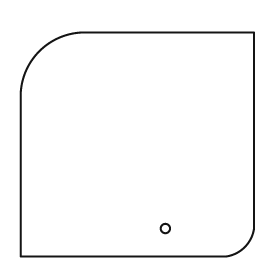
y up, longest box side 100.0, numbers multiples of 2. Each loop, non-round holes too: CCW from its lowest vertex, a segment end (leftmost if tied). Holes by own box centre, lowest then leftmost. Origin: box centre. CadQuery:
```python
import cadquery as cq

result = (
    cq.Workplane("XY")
    .moveTo(-50.0, -48.0)
    .lineTo(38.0, -48.0)
    .threePointArc((46.0, -44.0), (50.0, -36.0))
    .lineTo(50.0, 48.0)
    .lineTo(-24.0, 48.0)
    .threePointArc((-42.0, 40.0), (-50.0, 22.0))
    .close()
    .moveTo(12.0, -36.0)
    .circle(2.0)
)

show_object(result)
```